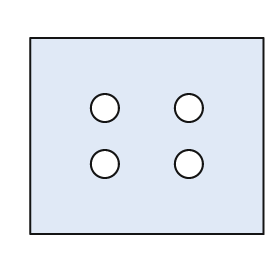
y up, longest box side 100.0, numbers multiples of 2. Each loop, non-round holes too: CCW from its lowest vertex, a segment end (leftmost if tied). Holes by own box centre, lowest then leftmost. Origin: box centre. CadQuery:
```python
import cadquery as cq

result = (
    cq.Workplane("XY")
    .moveTo(-50.0, -42.0)
    .lineTo(50.0, -42.0)
    .lineTo(50.0, 42.0)
    .lineTo(-50.0, 42.0)
    .close()
    .moveTo(-18.0, -12.0)
    .circle(6.0)
    .moveTo(18.0, -12.0)
    .circle(6.0)
    .moveTo(-18.0, 12.0)
    .circle(6.0)
    .moveTo(18.0, 12.0)
    .circle(6.0)
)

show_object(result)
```